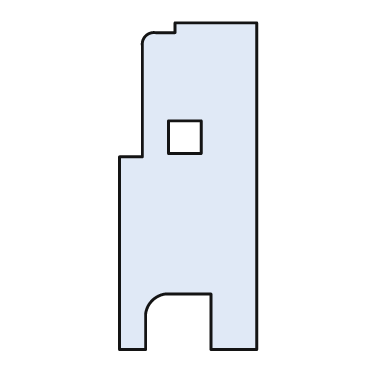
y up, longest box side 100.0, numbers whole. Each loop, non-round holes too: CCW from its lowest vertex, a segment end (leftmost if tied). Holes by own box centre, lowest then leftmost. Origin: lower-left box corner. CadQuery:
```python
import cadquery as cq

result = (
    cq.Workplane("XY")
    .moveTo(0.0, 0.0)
    .lineTo(8.0, 0.0)
    .lineTo(8.0, 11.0)
    .threePointArc((10.0, 15.0), (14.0, 17.0))
    .lineTo(28.0, 17.0)
    .lineTo(28.0, 0.0)
    .lineTo(42.0, 0.0)
    .lineTo(42.0, 100.0)
    .lineTo(17.0, 100.0)
    .lineTo(17.0, 97.0)
    .lineTo(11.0, 97.0)
    .threePointArc((8.0, 96.0), (7.0, 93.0))
    .lineTo(7.0, 59.0)
    .lineTo(0.0, 59.0)
    .close()
    .moveTo(15.0, 60.0)
    .lineTo(25.0, 60.0)
    .lineTo(25.0, 70.0)
    .lineTo(15.0, 70.0)
    .close()
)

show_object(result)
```